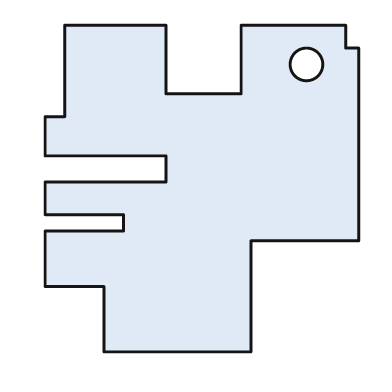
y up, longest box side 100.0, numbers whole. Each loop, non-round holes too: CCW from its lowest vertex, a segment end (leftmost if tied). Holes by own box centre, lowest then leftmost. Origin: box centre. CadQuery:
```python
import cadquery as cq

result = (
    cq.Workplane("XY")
    .moveTo(-30.0, -50.0)
    .lineTo(15.0, -50.0)
    .lineTo(15.0, -16.0)
    .lineTo(48.0, -16.0)
    .lineTo(48.0, 43.0)
    .lineTo(44.0, 43.0)
    .lineTo(44.0, 50.0)
    .lineTo(12.0, 50.0)
    .lineTo(12.0, 29.0)
    .lineTo(-11.0, 29.0)
    .lineTo(-11.0, 50.0)
    .lineTo(-42.0, 50.0)
    .lineTo(-42.0, 22.0)
    .lineTo(-48.0, 22.0)
    .lineTo(-48.0, 10.0)
    .lineTo(-11.0, 10.0)
    .lineTo(-11.0, 2.0)
    .lineTo(-48.0, 2.0)
    .lineTo(-48.0, -8.0)
    .lineTo(-24.0, -8.0)
    .lineTo(-24.0, -13.0)
    .lineTo(-48.0, -13.0)
    .lineTo(-48.0, -30.0)
    .lineTo(-30.0, -30.0)
    .close()
    .moveTo(32.0, 38.0)
    .circle(5.0)
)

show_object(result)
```